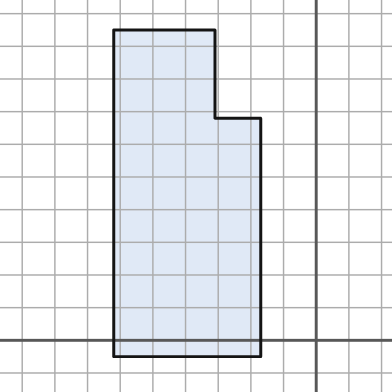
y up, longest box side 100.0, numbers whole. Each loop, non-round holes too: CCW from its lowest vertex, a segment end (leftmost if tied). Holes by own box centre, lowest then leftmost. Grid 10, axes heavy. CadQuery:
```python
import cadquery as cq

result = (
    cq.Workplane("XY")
    .moveTo(-62.0, -5.0)
    .lineTo(-17.0, -5.0)
    .lineTo(-17.0, 68.0)
    .lineTo(-31.0, 68.0)
    .lineTo(-31.0, 95.0)
    .lineTo(-62.0, 95.0)
    .close()
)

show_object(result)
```